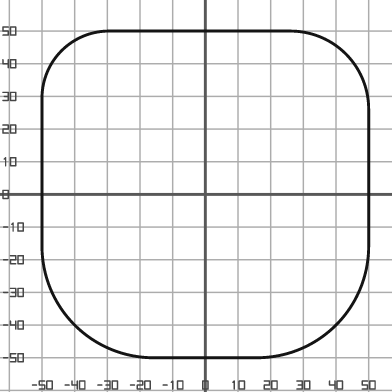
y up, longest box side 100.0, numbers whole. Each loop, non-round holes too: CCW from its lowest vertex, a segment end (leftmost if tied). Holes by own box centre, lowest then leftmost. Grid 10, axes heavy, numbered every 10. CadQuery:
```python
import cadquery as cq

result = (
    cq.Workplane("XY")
    .moveTo(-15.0, -50.0)
    .lineTo(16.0, -50.0)
    .threePointArc((40.0, -40.0), (50.0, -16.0))
    .lineTo(50.0, 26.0)
    .threePointArc((43.0, 43.0), (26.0, 50.0))
    .lineTo(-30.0, 50.0)
    .threePointArc((-44.0, 44.0), (-50.0, 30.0))
    .lineTo(-50.0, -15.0)
    .threePointArc((-40.0, -40.0), (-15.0, -50.0))
    .close()
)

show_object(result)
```